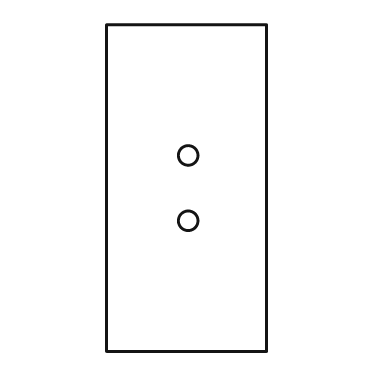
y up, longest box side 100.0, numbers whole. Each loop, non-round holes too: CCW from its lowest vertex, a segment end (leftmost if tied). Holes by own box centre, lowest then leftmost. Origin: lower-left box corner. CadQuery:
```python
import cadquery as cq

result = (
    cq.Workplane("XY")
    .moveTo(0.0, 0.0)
    .lineTo(49.0, 0.0)
    .lineTo(49.0, 100.0)
    .lineTo(0.0, 100.0)
    .close()
    .moveTo(25.0, 40.0)
    .circle(3.0)
    .moveTo(25.0, 60.0)
    .circle(3.0)
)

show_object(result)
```